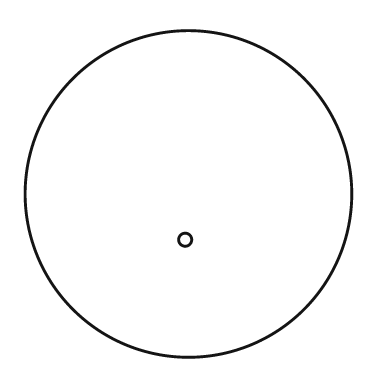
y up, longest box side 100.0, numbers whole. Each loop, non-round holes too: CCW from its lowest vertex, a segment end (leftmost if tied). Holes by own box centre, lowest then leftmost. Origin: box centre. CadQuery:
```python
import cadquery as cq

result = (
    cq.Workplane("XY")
    .moveTo(0.0, 0.0)
    .circle(50.0)
    .moveTo(-1.0, -14.0)
    .circle(2.0)
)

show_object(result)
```